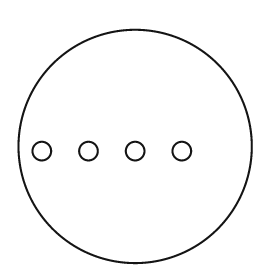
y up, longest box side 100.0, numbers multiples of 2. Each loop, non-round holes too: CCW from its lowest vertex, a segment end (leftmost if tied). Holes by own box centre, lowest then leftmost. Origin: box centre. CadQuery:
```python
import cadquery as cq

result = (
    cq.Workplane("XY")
    .moveTo(0.0, 0.0)
    .circle(50.0)
    .moveTo(-40.0, -2.0)
    .circle(4.0)
    .moveTo(-20.0, -2.0)
    .circle(4.0)
    .moveTo(0.0, -2.0)
    .circle(4.0)
    .moveTo(20.0, -2.0)
    .circle(4.0)
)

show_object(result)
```